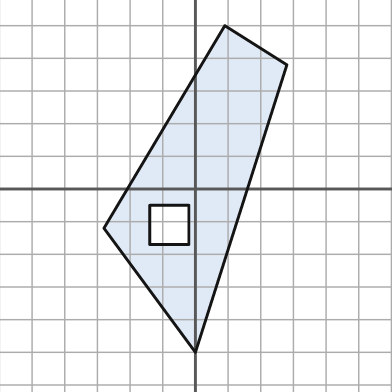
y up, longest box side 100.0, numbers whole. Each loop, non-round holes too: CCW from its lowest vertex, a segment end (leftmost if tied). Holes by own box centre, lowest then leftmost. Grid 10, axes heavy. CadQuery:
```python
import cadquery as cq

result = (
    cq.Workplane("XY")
    .moveTo(0.0, -50.0)
    .lineTo(28.0, 38.0)
    .lineTo(9.0, 50.0)
    .lineTo(-28.0, -12.0)
    .close()
    .moveTo(-14.0, -17.0)
    .lineTo(-2.0, -17.0)
    .lineTo(-2.0, -5.0)
    .lineTo(-14.0, -5.0)
    .close()
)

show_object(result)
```